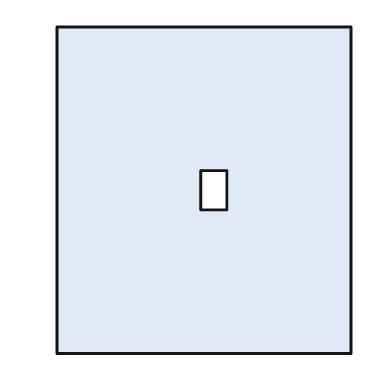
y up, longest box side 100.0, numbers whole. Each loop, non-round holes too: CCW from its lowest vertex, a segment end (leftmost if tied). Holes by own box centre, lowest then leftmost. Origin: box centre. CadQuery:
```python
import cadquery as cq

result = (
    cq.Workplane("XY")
    .moveTo(-45.0, -50.0)
    .lineTo(45.0, -50.0)
    .lineTo(45.0, 50.0)
    .lineTo(-45.0, 50.0)
    .close()
    .moveTo(-1.0, -6.0)
    .lineTo(7.0, -6.0)
    .lineTo(7.0, 6.0)
    .lineTo(-1.0, 6.0)
    .close()
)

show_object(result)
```